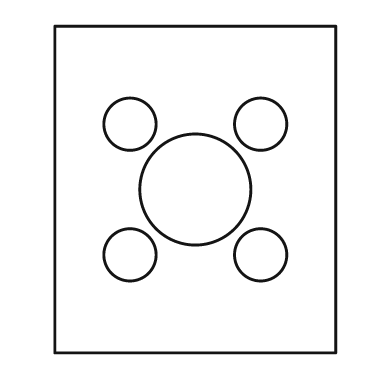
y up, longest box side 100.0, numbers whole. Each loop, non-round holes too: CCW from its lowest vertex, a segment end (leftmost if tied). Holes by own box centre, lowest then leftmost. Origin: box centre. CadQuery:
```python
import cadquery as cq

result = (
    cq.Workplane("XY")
    .moveTo(-43.0, -50.0)
    .lineTo(43.0, -50.0)
    .lineTo(43.0, 50.0)
    .lineTo(-43.0, 50.0)
    .close()
    .moveTo(-20.0, -20.0)
    .circle(8.0)
    .moveTo(20.0, -20.0)
    .circle(8.0)
    .moveTo(0.0, 0.0)
    .circle(17.0)
    .moveTo(-20.0, 20.0)
    .circle(8.0)
    .moveTo(20.0, 20.0)
    .circle(8.0)
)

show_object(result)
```